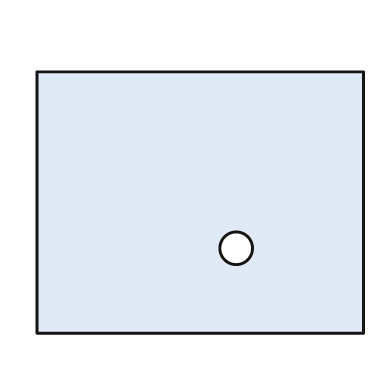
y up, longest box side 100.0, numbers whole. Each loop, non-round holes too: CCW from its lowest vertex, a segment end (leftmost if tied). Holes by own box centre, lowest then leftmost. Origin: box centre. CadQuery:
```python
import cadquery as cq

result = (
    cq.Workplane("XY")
    .moveTo(-50.0, -40.0)
    .lineTo(50.0, -40.0)
    .lineTo(50.0, 40.0)
    .lineTo(-50.0, 40.0)
    .close()
    .moveTo(11.0, -14.0)
    .circle(5.0)
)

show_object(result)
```